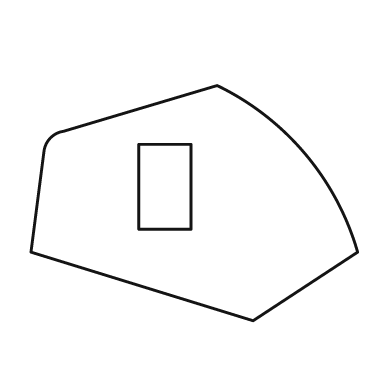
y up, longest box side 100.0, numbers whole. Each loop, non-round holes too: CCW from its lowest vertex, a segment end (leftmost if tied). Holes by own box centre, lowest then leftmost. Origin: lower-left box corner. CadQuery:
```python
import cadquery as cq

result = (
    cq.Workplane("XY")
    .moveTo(68.0, 0.0)
    .lineTo(100.0, 21.0)
    .threePointArc((84.0, 51.0), (57.0, 72.0))
    .lineTo(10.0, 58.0)
    .threePointArc((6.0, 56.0), (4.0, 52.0))
    .lineTo(0.0, 21.0)
    .close()
    .moveTo(33.0, 28.0)
    .lineTo(49.0, 28.0)
    .lineTo(49.0, 54.0)
    .lineTo(33.0, 54.0)
    .close()
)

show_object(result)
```